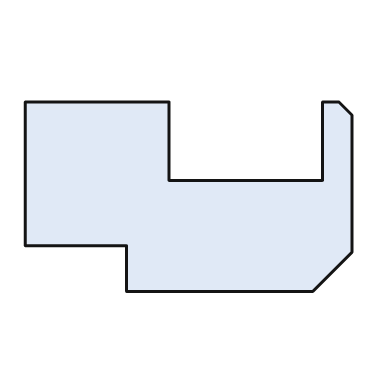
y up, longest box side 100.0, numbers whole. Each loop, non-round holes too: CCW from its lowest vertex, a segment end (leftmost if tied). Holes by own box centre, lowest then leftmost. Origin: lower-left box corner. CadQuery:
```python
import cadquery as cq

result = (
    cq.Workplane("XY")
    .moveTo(31.0, 0.0)
    .lineTo(88.0, 0.0)
    .lineTo(100.0, 12.0)
    .lineTo(100.0, 54.0)
    .lineTo(96.0, 58.0)
    .lineTo(91.0, 58.0)
    .lineTo(91.0, 34.0)
    .lineTo(44.0, 34.0)
    .lineTo(44.0, 58.0)
    .lineTo(0.0, 58.0)
    .lineTo(0.0, 14.0)
    .lineTo(31.0, 14.0)
    .close()
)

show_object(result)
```